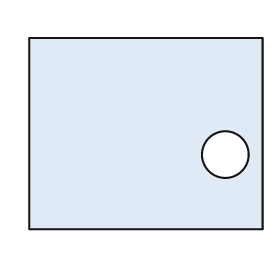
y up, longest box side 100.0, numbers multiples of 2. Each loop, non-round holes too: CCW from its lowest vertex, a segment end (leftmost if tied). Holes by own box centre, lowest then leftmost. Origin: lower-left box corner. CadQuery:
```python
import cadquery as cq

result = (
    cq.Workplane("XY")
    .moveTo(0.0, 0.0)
    .lineTo(100.0, 0.0)
    .lineTo(100.0, 82.0)
    .lineTo(0.0, 82.0)
    .close()
    .moveTo(84.0, 32.0)
    .circle(10.0)
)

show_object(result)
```